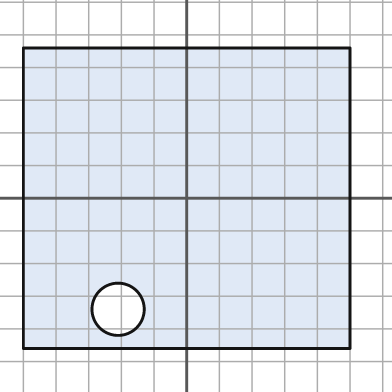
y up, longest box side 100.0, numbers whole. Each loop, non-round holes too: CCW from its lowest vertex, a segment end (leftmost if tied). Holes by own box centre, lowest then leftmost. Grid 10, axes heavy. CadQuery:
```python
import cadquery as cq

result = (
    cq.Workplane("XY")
    .moveTo(-50.0, -46.0)
    .lineTo(50.0, -46.0)
    .lineTo(50.0, 46.0)
    .lineTo(-50.0, 46.0)
    .close()
    .moveTo(-21.0, -34.0)
    .circle(8.0)
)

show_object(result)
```